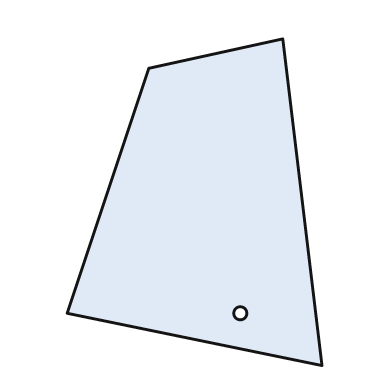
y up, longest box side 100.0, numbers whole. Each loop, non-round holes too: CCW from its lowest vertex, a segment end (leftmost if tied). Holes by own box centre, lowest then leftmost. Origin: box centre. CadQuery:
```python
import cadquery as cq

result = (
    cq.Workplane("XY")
    .moveTo(39.0, -50.0)
    .lineTo(27.0, 50.0)
    .lineTo(-14.0, 41.0)
    .lineTo(-39.0, -34.0)
    .close()
    .moveTo(14.0, -34.0)
    .circle(2.0)
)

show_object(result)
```